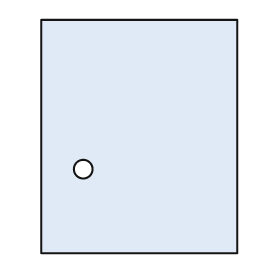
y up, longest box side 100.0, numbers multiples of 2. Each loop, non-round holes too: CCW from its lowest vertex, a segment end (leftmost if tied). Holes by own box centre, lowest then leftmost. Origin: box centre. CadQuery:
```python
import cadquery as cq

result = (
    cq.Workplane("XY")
    .moveTo(-42.0, -50.0)
    .lineTo(42.0, -50.0)
    .lineTo(42.0, 50.0)
    .lineTo(-42.0, 50.0)
    .close()
    .moveTo(-24.0, -14.0)
    .circle(4.0)
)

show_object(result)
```